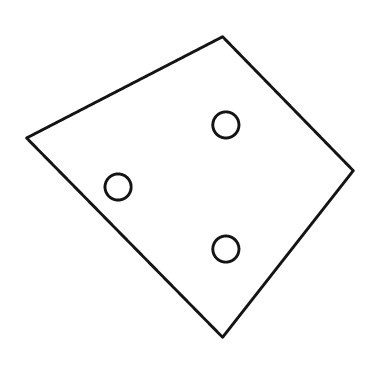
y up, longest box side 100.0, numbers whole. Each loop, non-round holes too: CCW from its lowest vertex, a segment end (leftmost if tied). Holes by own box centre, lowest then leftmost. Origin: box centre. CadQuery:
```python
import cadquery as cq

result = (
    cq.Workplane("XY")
    .moveTo(10.0, -46.0)
    .lineTo(50.0, 5.0)
    .lineTo(10.0, 46.0)
    .lineTo(-50.0, 15.0)
    .close()
    .moveTo(11.0, -19.0)
    .circle(4.0)
    .moveTo(-22.0, 0.0)
    .circle(4.0)
    .moveTo(11.0, 19.0)
    .circle(4.0)
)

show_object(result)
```